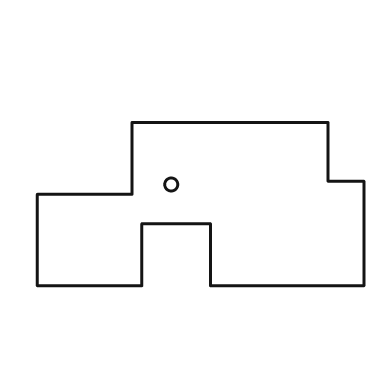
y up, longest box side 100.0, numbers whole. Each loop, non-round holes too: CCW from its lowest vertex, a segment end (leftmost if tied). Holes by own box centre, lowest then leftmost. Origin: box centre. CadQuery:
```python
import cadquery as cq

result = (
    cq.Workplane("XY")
    .moveTo(-50.0, -25.0)
    .lineTo(-18.0, -25.0)
    .lineTo(-18.0, -6.0)
    .lineTo(3.0, -6.0)
    .lineTo(3.0, -25.0)
    .lineTo(50.0, -25.0)
    .lineTo(50.0, 7.0)
    .lineTo(39.0, 7.0)
    .lineTo(39.0, 25.0)
    .lineTo(-21.0, 25.0)
    .lineTo(-21.0, 3.0)
    .lineTo(-50.0, 3.0)
    .close()
    .moveTo(-9.0, 6.0)
    .circle(2.0)
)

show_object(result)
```